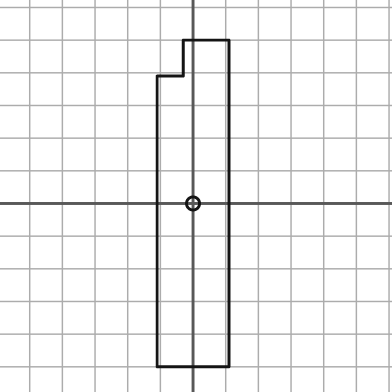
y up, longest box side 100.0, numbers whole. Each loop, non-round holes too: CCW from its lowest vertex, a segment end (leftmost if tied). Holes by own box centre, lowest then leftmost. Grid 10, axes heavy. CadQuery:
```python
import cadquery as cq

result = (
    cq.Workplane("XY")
    .moveTo(-11.0, -50.0)
    .lineTo(11.0, -50.0)
    .lineTo(11.0, 50.0)
    .lineTo(-3.0, 50.0)
    .lineTo(-3.0, 39.0)
    .lineTo(-11.0, 39.0)
    .close()
    .moveTo(0.0, 0.0)
    .circle(2.0)
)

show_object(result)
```